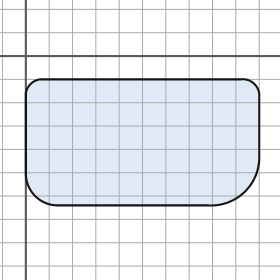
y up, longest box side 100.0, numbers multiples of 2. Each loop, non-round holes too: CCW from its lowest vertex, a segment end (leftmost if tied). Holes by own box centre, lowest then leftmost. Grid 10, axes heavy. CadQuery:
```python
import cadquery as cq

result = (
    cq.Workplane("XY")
    .moveTo(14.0, -64.0)
    .lineTo(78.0, -64.0)
    .threePointArc((94.0, -58.0), (100.0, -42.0))
    .lineTo(100.0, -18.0)
    .threePointArc((98.0, -12.0), (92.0, -10.0))
    .lineTo(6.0, -10.0)
    .threePointArc((2.0, -12.0), (0.0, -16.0))
    .lineTo(0.0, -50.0)
    .threePointArc((4.0, -60.0), (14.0, -64.0))
    .close()
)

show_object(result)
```